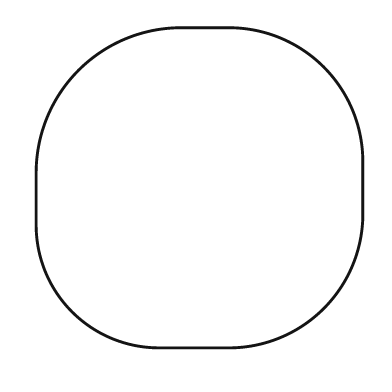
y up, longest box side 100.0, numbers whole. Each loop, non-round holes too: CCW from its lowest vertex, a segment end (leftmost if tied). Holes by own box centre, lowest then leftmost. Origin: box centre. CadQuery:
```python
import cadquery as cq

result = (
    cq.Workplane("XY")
    .moveTo(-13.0, -49.0)
    .lineTo(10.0, -49.0)
    .threePointArc((38.0, -37.0), (50.0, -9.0))
    .lineTo(50.0, 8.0)
    .threePointArc((38.0, 37.0), (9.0, 49.0))
    .lineTo(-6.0, 49.0)
    .threePointArc((-37.0, 36.0), (-50.0, 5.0))
    .lineTo(-50.0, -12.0)
    .threePointArc((-39.0, -38.0), (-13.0, -49.0))
    .close()
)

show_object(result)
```